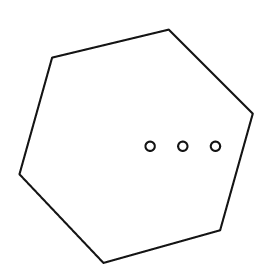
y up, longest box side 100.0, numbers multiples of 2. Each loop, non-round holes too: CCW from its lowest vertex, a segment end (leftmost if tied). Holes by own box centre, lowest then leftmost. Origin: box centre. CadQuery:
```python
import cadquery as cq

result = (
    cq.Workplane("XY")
    .moveTo(-14.0, -50.0)
    .lineTo(36.0, -36.0)
    .lineTo(50.0, 14.0)
    .lineTo(14.0, 50.0)
    .lineTo(-36.0, 38.0)
    .lineTo(-50.0, -12.0)
    .close()
    .moveTo(6.0, 0.0)
    .circle(2.0)
    .moveTo(20.0, 0.0)
    .circle(2.0)
    .moveTo(34.0, 0.0)
    .circle(2.0)
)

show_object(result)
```